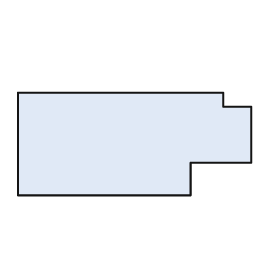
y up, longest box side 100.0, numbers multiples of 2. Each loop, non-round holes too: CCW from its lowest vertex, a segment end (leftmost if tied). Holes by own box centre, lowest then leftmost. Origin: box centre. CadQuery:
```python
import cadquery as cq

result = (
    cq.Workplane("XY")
    .moveTo(-50.0, -22.0)
    .lineTo(24.0, -22.0)
    .lineTo(24.0, -8.0)
    .lineTo(50.0, -8.0)
    .lineTo(50.0, 16.0)
    .lineTo(38.0, 16.0)
    .lineTo(38.0, 22.0)
    .lineTo(-50.0, 22.0)
    .close()
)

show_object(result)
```